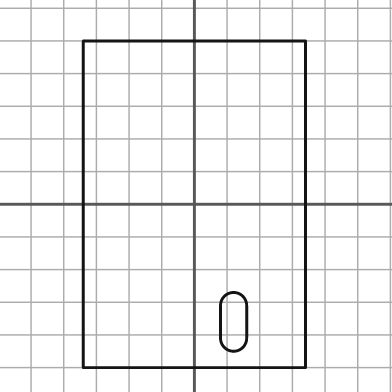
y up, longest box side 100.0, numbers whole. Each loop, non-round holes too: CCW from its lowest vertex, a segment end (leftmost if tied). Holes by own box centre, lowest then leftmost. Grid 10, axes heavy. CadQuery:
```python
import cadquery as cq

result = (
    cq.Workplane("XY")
    .moveTo(-34.0, -50.0)
    .lineTo(34.0, -50.0)
    .lineTo(34.0, 50.0)
    .lineTo(-34.0, 50.0)
    .close()
    .moveTo(8.0, -41.0)
    .threePointArc((12.0, -45.0), (16.0, -41.0))
    .lineTo(16.0, -31.0)
    .threePointArc((12.0, -27.0), (8.0, -31.0))
    .close()
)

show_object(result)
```